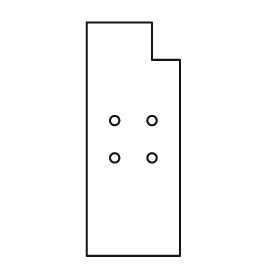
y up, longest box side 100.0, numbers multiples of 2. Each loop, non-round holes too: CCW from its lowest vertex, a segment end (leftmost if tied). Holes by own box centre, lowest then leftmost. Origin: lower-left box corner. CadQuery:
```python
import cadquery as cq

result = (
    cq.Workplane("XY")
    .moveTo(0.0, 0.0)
    .lineTo(40.0, 0.0)
    .lineTo(40.0, 84.0)
    .lineTo(28.0, 84.0)
    .lineTo(28.0, 100.0)
    .lineTo(0.0, 100.0)
    .close()
    .moveTo(12.0, 42.0)
    .circle(2.0)
    .moveTo(28.0, 42.0)
    .circle(2.0)
    .moveTo(12.0, 58.0)
    .circle(2.0)
    .moveTo(28.0, 58.0)
    .circle(2.0)
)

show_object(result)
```